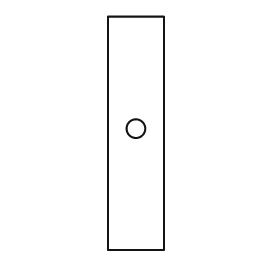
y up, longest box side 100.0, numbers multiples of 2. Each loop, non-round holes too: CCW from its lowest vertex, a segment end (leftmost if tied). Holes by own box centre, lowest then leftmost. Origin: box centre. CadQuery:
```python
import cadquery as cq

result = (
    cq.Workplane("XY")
    .moveTo(-12.0, -50.0)
    .lineTo(12.0, -50.0)
    .lineTo(12.0, 50.0)
    .lineTo(-12.0, 50.0)
    .close()
    .moveTo(0.0, 2.0)
    .circle(4.0)
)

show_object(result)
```